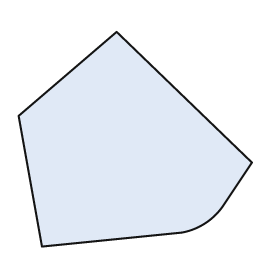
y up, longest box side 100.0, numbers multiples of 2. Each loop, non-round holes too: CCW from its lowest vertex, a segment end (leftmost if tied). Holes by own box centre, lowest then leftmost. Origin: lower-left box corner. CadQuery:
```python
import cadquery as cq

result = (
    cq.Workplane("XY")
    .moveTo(10.0, 0.0)
    .lineTo(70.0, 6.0)
    .threePointArc((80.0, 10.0), (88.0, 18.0))
    .lineTo(100.0, 36.0)
    .lineTo(42.0, 92.0)
    .lineTo(0.0, 56.0)
    .close()
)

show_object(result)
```